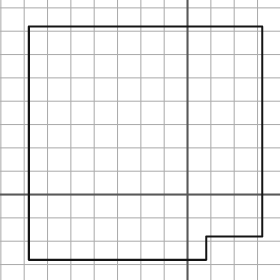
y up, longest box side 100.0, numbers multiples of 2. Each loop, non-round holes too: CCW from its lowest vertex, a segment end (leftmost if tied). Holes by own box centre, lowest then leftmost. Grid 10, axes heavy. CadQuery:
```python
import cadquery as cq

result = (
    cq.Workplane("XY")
    .moveTo(-68.0, -28.0)
    .lineTo(8.0, -28.0)
    .lineTo(8.0, -18.0)
    .lineTo(32.0, -18.0)
    .lineTo(32.0, 72.0)
    .lineTo(-68.0, 72.0)
    .close()
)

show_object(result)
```